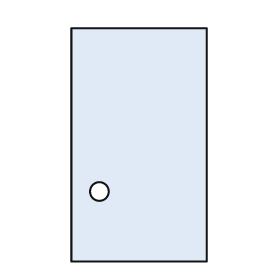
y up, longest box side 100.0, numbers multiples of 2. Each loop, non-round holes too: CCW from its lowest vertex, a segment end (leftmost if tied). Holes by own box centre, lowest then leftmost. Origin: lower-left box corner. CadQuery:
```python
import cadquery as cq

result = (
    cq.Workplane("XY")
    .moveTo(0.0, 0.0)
    .lineTo(58.0, 0.0)
    .lineTo(58.0, 100.0)
    .lineTo(0.0, 100.0)
    .close()
    .moveTo(12.0, 30.0)
    .circle(4.0)
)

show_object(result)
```